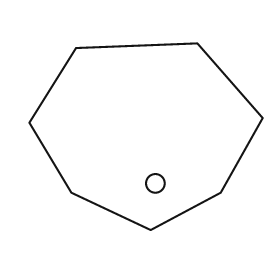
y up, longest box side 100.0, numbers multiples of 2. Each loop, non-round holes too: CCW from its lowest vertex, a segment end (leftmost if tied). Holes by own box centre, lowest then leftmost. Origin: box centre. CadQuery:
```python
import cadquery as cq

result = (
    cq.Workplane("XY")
    .moveTo(2.0, -40.0)
    .lineTo(32.0, -24.0)
    .lineTo(50.0, 8.0)
    .lineTo(22.0, 40.0)
    .lineTo(-30.0, 38.0)
    .lineTo(-50.0, 6.0)
    .lineTo(-32.0, -24.0)
    .close()
    .moveTo(4.0, -20.0)
    .circle(4.0)
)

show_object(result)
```